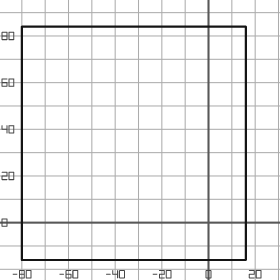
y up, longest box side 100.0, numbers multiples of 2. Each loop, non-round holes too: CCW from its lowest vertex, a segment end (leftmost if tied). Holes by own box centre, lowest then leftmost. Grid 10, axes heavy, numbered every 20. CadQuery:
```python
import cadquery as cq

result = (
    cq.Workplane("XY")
    .moveTo(-80.0, -16.0)
    .lineTo(16.0, -16.0)
    .lineTo(16.0, 84.0)
    .lineTo(-80.0, 84.0)
    .close()
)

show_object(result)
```